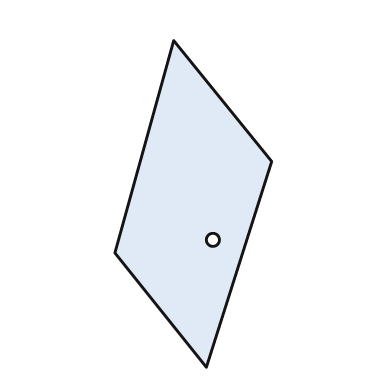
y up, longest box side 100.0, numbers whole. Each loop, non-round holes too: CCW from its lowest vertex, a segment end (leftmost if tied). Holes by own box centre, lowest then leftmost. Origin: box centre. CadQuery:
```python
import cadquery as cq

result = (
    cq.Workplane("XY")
    .moveTo(4.0, -50.0)
    .lineTo(24.0, 13.0)
    .lineTo(-6.0, 50.0)
    .lineTo(-24.0, -15.0)
    .close()
    .moveTo(6.0, -11.0)
    .circle(2.0)
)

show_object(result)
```